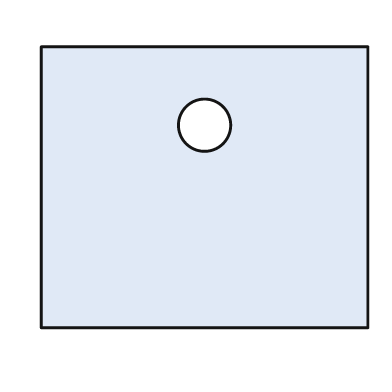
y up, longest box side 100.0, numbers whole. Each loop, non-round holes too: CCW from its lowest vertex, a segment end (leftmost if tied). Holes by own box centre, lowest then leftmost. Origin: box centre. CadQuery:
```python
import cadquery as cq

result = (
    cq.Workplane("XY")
    .moveTo(-50.0, -43.0)
    .lineTo(50.0, -43.0)
    .lineTo(50.0, 43.0)
    .lineTo(-50.0, 43.0)
    .close()
    .moveTo(0.0, 19.0)
    .circle(8.0)
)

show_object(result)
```